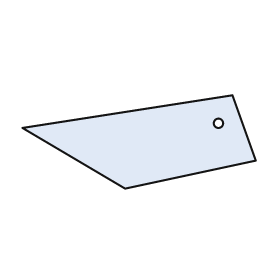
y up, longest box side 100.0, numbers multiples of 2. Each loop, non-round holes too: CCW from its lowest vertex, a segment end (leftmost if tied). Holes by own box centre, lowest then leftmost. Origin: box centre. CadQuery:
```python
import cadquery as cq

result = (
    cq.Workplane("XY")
    .moveTo(-6.0, -20.0)
    .lineTo(50.0, -8.0)
    .lineTo(40.0, 20.0)
    .lineTo(-50.0, 6.0)
    .close()
    .moveTo(34.0, 8.0)
    .circle(2.0)
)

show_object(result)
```